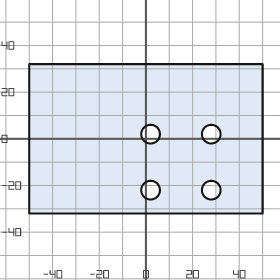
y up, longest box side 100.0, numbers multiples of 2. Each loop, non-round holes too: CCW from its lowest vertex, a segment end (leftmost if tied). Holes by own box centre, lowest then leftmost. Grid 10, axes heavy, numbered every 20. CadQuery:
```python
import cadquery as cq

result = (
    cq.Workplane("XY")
    .moveTo(-50.0, -32.0)
    .lineTo(50.0, -32.0)
    .lineTo(50.0, 32.0)
    .lineTo(-50.0, 32.0)
    .close()
    .moveTo(2.0, -22.0)
    .circle(4.0)
    .moveTo(28.0, -22.0)
    .circle(4.0)
    .moveTo(2.0, 2.0)
    .circle(4.0)
    .moveTo(28.0, 2.0)
    .circle(4.0)
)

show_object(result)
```